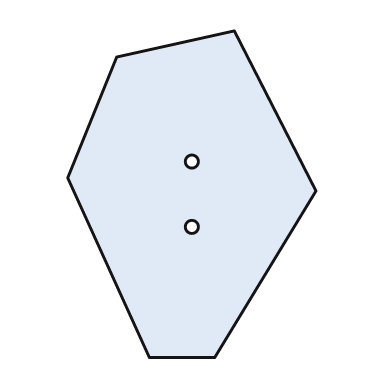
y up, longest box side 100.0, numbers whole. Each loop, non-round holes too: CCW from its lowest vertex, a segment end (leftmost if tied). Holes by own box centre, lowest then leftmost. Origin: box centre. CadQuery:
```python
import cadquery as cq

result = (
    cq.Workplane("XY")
    .moveTo(-13.0, -50.0)
    .lineTo(7.0, -50.0)
    .lineTo(38.0, 1.0)
    .lineTo(13.0, 50.0)
    .lineTo(-23.0, 42.0)
    .lineTo(-38.0, 5.0)
    .close()
    .moveTo(0.0, -10.0)
    .circle(2.0)
    .moveTo(0.0, 10.0)
    .circle(2.0)
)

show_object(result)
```